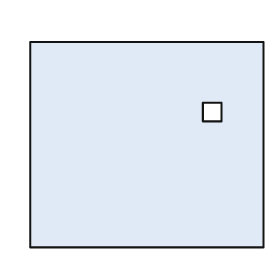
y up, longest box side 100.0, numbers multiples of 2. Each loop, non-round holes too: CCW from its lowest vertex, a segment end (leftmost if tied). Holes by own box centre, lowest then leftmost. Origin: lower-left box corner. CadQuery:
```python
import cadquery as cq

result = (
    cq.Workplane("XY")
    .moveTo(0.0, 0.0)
    .lineTo(100.0, 0.0)
    .lineTo(100.0, 88.0)
    .lineTo(0.0, 88.0)
    .close()
    .moveTo(74.0, 54.0)
    .lineTo(82.0, 54.0)
    .lineTo(82.0, 62.0)
    .lineTo(74.0, 62.0)
    .close()
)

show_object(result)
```